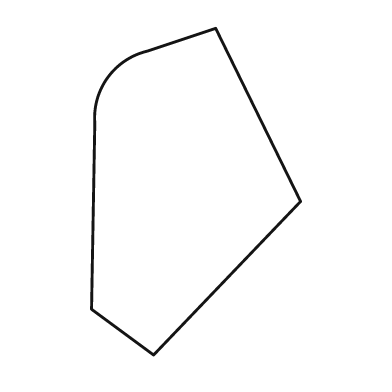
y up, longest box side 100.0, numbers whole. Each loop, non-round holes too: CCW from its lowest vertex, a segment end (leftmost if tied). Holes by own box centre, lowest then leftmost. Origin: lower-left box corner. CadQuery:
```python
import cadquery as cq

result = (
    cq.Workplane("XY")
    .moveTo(19.0, 0.0)
    .lineTo(64.0, 47.0)
    .lineTo(38.0, 100.0)
    .lineTo(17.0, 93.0)
    .threePointArc((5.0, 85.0), (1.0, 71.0))
    .lineTo(0.0, 14.0)
    .close()
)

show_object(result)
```